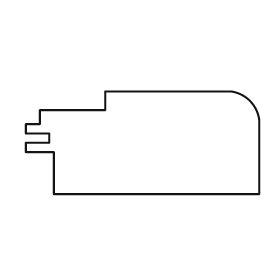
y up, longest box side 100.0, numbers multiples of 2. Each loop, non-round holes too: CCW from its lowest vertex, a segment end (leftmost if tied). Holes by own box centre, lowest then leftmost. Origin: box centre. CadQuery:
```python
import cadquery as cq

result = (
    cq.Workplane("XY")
    .moveTo(-38.0, -22.0)
    .lineTo(50.0, -22.0)
    .lineTo(50.0, 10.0)
    .threePointArc((46.0, 18.0), (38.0, 22.0))
    .lineTo(-16.0, 22.0)
    .lineTo(-16.0, 14.0)
    .lineTo(-44.0, 14.0)
    .lineTo(-44.0, 8.0)
    .lineTo(-50.0, 8.0)
    .lineTo(-50.0, 4.0)
    .lineTo(-40.0, 4.0)
    .lineTo(-40.0, 0.0)
    .lineTo(-50.0, 0.0)
    .lineTo(-50.0, -4.0)
    .lineTo(-38.0, -4.0)
    .close()
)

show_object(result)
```